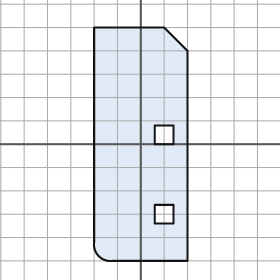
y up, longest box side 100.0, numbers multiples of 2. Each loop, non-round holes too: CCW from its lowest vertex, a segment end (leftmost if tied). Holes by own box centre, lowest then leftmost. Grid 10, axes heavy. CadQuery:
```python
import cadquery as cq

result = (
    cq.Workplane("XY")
    .moveTo(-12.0, -50.0)
    .lineTo(20.0, -50.0)
    .lineTo(20.0, 40.0)
    .lineTo(10.0, 50.0)
    .lineTo(-20.0, 50.0)
    .lineTo(-20.0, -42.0)
    .threePointArc((-18.0, -48.0), (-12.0, -50.0))
    .close()
    .moveTo(6.0, -34.0)
    .lineTo(14.0, -34.0)
    .lineTo(14.0, -26.0)
    .lineTo(6.0, -26.0)
    .close()
    .moveTo(6.0, 0.0)
    .lineTo(14.0, 0.0)
    .lineTo(14.0, 8.0)
    .lineTo(6.0, 8.0)
    .close()
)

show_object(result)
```